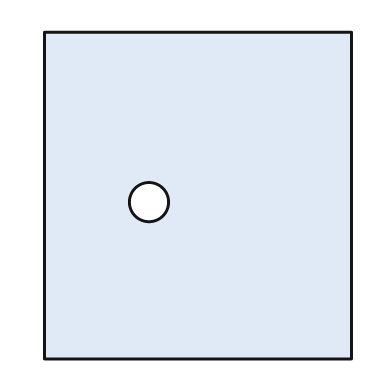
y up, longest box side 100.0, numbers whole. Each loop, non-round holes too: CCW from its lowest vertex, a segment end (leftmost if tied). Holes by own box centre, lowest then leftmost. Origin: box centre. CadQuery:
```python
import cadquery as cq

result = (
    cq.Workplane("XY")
    .moveTo(-47.0, -50.0)
    .lineTo(47.0, -50.0)
    .lineTo(47.0, 50.0)
    .lineTo(-47.0, 50.0)
    .close()
    .moveTo(-15.0, -2.0)
    .circle(6.0)
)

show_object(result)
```